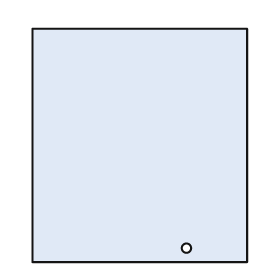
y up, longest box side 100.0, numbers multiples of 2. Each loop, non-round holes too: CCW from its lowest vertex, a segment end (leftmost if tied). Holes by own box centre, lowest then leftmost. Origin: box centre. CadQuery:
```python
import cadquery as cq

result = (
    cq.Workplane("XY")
    .moveTo(-46.0, -50.0)
    .lineTo(46.0, -50.0)
    .lineTo(46.0, 50.0)
    .lineTo(-46.0, 50.0)
    .close()
    .moveTo(20.0, -44.0)
    .circle(2.0)
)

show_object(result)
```